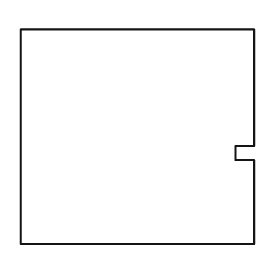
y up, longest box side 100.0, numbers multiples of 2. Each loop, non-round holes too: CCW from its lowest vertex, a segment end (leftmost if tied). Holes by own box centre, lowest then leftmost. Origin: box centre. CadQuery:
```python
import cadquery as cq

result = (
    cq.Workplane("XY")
    .moveTo(-50.0, -46.0)
    .lineTo(50.0, -46.0)
    .lineTo(50.0, -10.0)
    .lineTo(42.0, -10.0)
    .lineTo(42.0, -4.0)
    .lineTo(50.0, -4.0)
    .lineTo(50.0, 46.0)
    .lineTo(-50.0, 46.0)
    .close()
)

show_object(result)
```